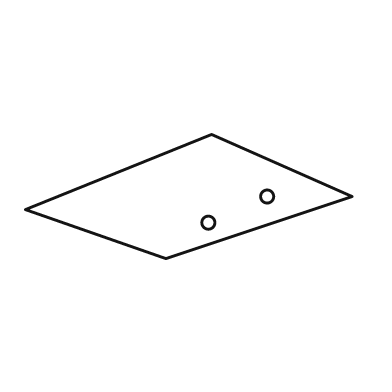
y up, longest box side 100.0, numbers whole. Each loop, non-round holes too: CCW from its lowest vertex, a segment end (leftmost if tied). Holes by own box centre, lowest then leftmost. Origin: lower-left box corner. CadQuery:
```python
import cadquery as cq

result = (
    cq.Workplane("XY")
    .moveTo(43.0, 0.0)
    .lineTo(100.0, 19.0)
    .lineTo(57.0, 38.0)
    .lineTo(0.0, 15.0)
    .close()
    .moveTo(56.0, 11.0)
    .circle(2.0)
    .moveTo(74.0, 19.0)
    .circle(2.0)
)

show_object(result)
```